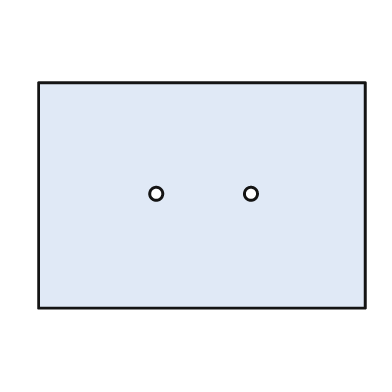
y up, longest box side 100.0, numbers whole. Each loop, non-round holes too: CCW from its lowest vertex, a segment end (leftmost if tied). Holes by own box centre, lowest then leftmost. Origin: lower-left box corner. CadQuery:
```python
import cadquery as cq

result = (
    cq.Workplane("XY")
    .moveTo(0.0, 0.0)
    .lineTo(100.0, 0.0)
    .lineTo(100.0, 69.0)
    .lineTo(0.0, 69.0)
    .close()
    .moveTo(36.0, 35.0)
    .circle(2.0)
    .moveTo(65.0, 35.0)
    .circle(2.0)
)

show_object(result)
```